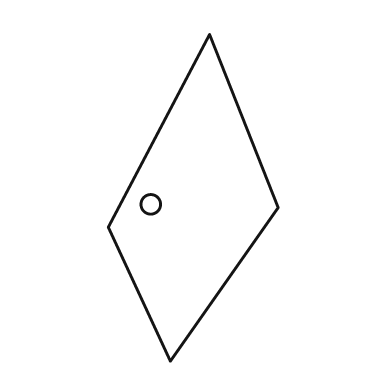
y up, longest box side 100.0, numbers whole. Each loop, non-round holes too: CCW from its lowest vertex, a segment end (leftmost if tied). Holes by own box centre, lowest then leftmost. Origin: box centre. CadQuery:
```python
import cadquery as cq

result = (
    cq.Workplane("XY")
    .moveTo(-7.0, -50.0)
    .lineTo(26.0, -3.0)
    .lineTo(5.0, 50.0)
    .lineTo(-26.0, -9.0)
    .close()
    .moveTo(-13.0, -2.0)
    .circle(3.0)
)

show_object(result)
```